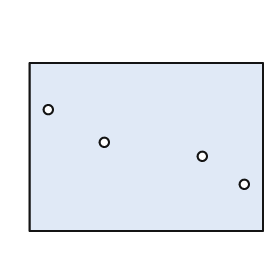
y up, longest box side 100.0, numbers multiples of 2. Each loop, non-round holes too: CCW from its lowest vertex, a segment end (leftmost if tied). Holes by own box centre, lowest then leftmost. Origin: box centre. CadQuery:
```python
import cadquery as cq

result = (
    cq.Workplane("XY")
    .moveTo(-50.0, -36.0)
    .lineTo(50.0, -36.0)
    .lineTo(50.0, 36.0)
    .lineTo(-50.0, 36.0)
    .close()
    .moveTo(42.0, -16.0)
    .circle(2.0)
    .moveTo(24.0, -4.0)
    .circle(2.0)
    .moveTo(-18.0, 2.0)
    .circle(2.0)
    .moveTo(-42.0, 16.0)
    .circle(2.0)
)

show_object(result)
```